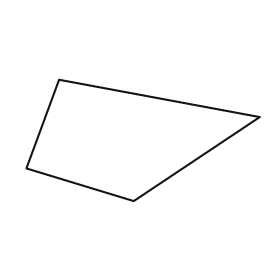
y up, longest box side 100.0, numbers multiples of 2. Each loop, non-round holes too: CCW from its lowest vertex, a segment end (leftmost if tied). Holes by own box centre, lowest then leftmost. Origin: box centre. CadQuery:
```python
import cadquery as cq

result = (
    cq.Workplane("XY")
    .moveTo(-4.0, -26.0)
    .lineTo(50.0, 10.0)
    .lineTo(-36.0, 26.0)
    .lineTo(-50.0, -12.0)
    .close()
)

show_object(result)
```